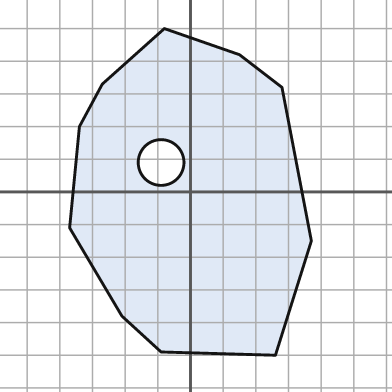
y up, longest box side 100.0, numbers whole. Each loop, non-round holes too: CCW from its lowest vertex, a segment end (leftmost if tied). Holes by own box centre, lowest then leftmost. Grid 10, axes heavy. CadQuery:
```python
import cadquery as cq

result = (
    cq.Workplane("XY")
    .moveTo(26.0, -50.0)
    .lineTo(37.0, -15.0)
    .lineTo(28.0, 32.0)
    .lineTo(15.0, 42.0)
    .lineTo(-8.0, 50.0)
    .lineTo(-27.0, 33.0)
    .lineTo(-34.0, 20.0)
    .lineTo(-37.0, -11.0)
    .lineTo(-21.0, -38.0)
    .lineTo(-9.0, -49.0)
    .close()
    .moveTo(-9.0, 9.0)
    .circle(7.0)
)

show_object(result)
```